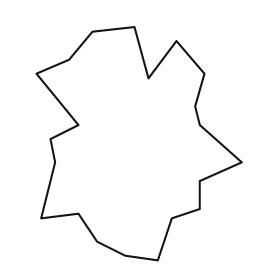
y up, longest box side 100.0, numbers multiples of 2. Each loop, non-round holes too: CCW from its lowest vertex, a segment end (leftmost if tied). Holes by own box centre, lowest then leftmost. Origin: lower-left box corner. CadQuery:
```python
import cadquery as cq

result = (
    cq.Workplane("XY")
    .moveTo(52.0, 0.0)
    .lineTo(58.0, 18.0)
    .lineTo(70.0, 22.0)
    .lineTo(70.0, 34.0)
    .lineTo(88.0, 42.0)
    .lineTo(70.0, 58.0)
    .lineTo(68.0, 66.0)
    .lineTo(72.0, 80.0)
    .lineTo(60.0, 94.0)
    .lineTo(48.0, 78.0)
    .lineTo(42.0, 100.0)
    .lineTo(24.0, 98.0)
    .lineTo(14.0, 86.0)
    .lineTo(0.0, 80.0)
    .lineTo(18.0, 58.0)
    .lineTo(6.0, 52.0)
    .lineTo(8.0, 42.0)
    .lineTo(2.0, 18.0)
    .lineTo(18.0, 20.0)
    .lineTo(26.0, 8.0)
    .lineTo(38.0, 2.0)
    .close()
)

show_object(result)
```